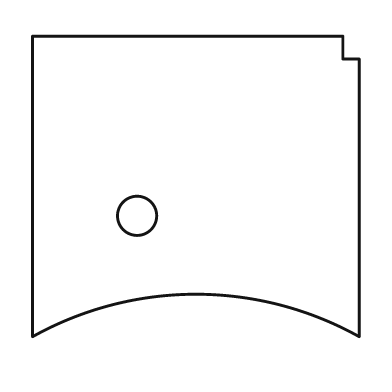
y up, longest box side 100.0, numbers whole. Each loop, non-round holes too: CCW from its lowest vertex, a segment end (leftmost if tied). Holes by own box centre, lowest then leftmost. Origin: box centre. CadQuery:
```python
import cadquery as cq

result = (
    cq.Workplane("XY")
    .moveTo(-50.0, -46.0)
    .threePointArc((0.0, -33.0), (50.0, -46.0))
    .lineTo(50.0, 39.0)
    .lineTo(45.0, 39.0)
    .lineTo(45.0, 46.0)
    .lineTo(-50.0, 46.0)
    .close()
    .moveTo(-18.0, -9.0)
    .circle(6.0)
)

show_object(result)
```